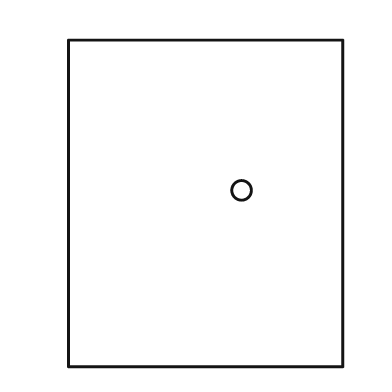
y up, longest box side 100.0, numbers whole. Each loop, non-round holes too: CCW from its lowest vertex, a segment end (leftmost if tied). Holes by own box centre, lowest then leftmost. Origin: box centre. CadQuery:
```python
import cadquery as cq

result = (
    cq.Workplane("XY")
    .moveTo(-42.0, -50.0)
    .lineTo(42.0, -50.0)
    .lineTo(42.0, 50.0)
    .lineTo(-42.0, 50.0)
    .close()
    .moveTo(11.0, 4.0)
    .circle(3.0)
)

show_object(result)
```